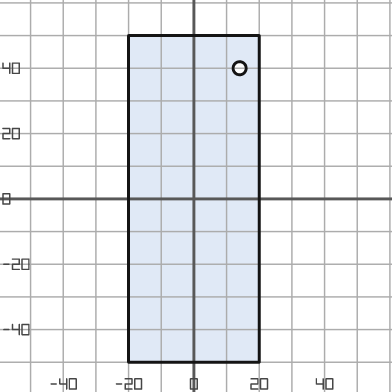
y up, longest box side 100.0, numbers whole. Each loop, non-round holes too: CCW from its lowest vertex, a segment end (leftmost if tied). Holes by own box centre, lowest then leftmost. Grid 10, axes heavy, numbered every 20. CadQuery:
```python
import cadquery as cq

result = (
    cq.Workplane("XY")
    .moveTo(-20.0, -50.0)
    .lineTo(20.0, -50.0)
    .lineTo(20.0, 50.0)
    .lineTo(-20.0, 50.0)
    .close()
    .moveTo(14.0, 40.0)
    .circle(2.0)
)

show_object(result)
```